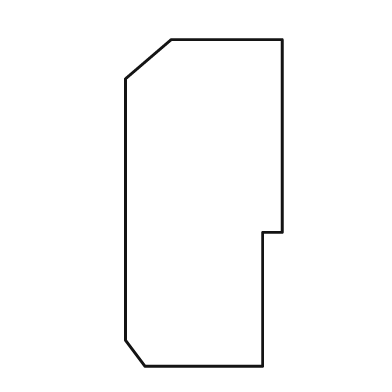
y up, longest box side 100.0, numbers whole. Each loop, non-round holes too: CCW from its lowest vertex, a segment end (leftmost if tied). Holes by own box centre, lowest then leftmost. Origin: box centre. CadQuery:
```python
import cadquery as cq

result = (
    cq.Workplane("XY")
    .moveTo(-18.0, -50.0)
    .lineTo(18.0, -50.0)
    .lineTo(18.0, -9.0)
    .lineTo(24.0, -9.0)
    .lineTo(24.0, 50.0)
    .lineTo(-10.0, 50.0)
    .lineTo(-24.0, 38.0)
    .lineTo(-24.0, -42.0)
    .close()
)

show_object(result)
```